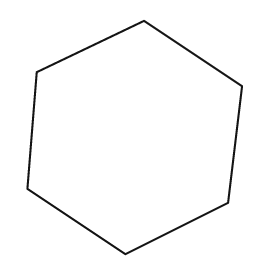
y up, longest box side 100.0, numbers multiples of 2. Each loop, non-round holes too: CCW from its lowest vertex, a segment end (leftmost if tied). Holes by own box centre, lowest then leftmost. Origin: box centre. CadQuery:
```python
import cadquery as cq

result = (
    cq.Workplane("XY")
    .moveTo(-4.0, -50.0)
    .lineTo(40.0, -28.0)
    .lineTo(46.0, 22.0)
    .lineTo(4.0, 50.0)
    .lineTo(-42.0, 28.0)
    .lineTo(-46.0, -22.0)
    .close()
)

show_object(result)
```